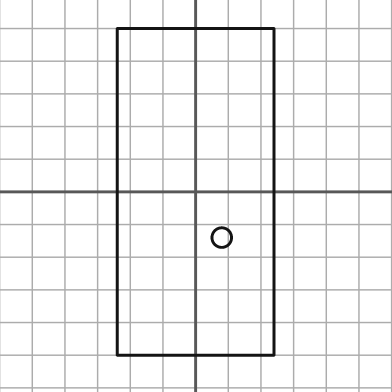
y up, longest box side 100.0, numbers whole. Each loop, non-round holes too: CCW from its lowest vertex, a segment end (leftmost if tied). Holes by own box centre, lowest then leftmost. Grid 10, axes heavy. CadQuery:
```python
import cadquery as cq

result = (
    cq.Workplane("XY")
    .moveTo(-24.0, -50.0)
    .lineTo(24.0, -50.0)
    .lineTo(24.0, 50.0)
    .lineTo(-24.0, 50.0)
    .close()
    .moveTo(8.0, -14.0)
    .circle(3.0)
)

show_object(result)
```